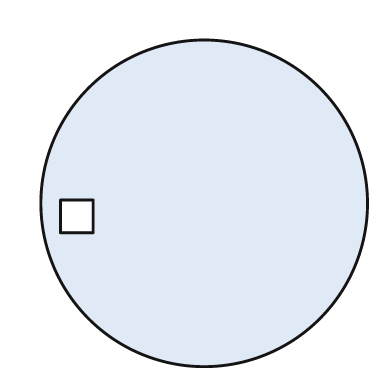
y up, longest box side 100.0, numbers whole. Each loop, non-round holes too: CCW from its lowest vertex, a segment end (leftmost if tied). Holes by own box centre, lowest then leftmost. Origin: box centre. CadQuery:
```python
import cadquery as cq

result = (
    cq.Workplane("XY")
    .moveTo(0.0, 0.0)
    .circle(50.0)
    .moveTo(-44.0, -9.0)
    .lineTo(-34.0, -9.0)
    .lineTo(-34.0, 1.0)
    .lineTo(-44.0, 1.0)
    .close()
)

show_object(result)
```